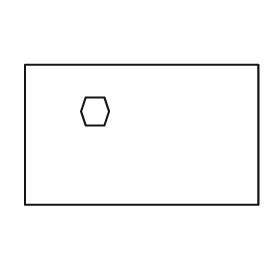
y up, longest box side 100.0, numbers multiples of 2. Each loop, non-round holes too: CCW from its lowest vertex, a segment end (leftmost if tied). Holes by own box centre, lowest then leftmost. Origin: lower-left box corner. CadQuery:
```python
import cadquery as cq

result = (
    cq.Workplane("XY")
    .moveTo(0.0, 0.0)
    .lineTo(100.0, 0.0)
    .lineTo(100.0, 60.0)
    .lineTo(0.0, 60.0)
    .close()
    .moveTo(26.0, 34.0)
    .lineTo(34.0, 34.0)
    .lineTo(36.0, 40.0)
    .lineTo(34.0, 46.0)
    .lineTo(26.0, 46.0)
    .lineTo(24.0, 40.0)
    .close()
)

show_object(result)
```